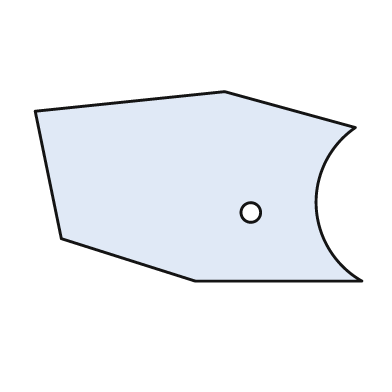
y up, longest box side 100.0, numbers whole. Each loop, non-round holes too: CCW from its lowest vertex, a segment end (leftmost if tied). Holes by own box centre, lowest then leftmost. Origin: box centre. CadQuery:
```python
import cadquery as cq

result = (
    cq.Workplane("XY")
    .moveTo(-1.0, -29.0)
    .lineTo(50.0, -29.0)
    .threePointArc((36.0, -6.0), (48.0, 18.0))
    .lineTo(8.0, 29.0)
    .lineTo(-50.0, 23.0)
    .lineTo(-42.0, -16.0)
    .close()
    .moveTo(16.0, -8.0)
    .circle(3.0)
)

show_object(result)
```